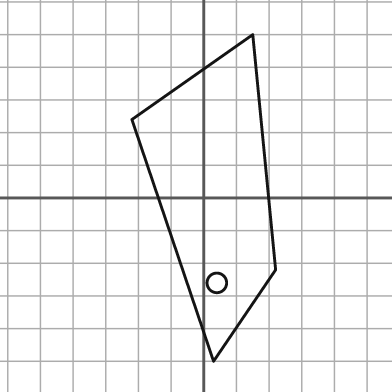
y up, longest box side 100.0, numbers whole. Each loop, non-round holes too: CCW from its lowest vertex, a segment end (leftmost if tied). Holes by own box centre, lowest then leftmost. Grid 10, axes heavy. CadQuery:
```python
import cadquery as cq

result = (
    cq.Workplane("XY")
    .moveTo(3.0, -50.0)
    .lineTo(22.0, -22.0)
    .lineTo(15.0, 50.0)
    .lineTo(-22.0, 24.0)
    .close()
    .moveTo(4.0, -26.0)
    .circle(3.0)
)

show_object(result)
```